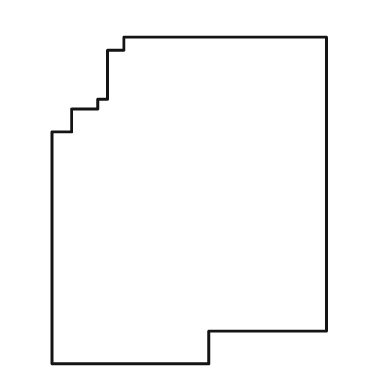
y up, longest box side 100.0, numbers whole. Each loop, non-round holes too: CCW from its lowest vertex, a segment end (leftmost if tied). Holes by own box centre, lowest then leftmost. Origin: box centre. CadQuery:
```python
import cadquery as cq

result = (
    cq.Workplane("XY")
    .moveTo(-42.0, -50.0)
    .lineTo(6.0, -50.0)
    .lineTo(6.0, -40.0)
    .lineTo(42.0, -40.0)
    .lineTo(42.0, 50.0)
    .lineTo(-20.0, 50.0)
    .lineTo(-20.0, 46.0)
    .lineTo(-25.0, 46.0)
    .lineTo(-25.0, 31.0)
    .lineTo(-28.0, 31.0)
    .lineTo(-28.0, 28.0)
    .lineTo(-36.0, 28.0)
    .lineTo(-36.0, 21.0)
    .lineTo(-42.0, 21.0)
    .close()
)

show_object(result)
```